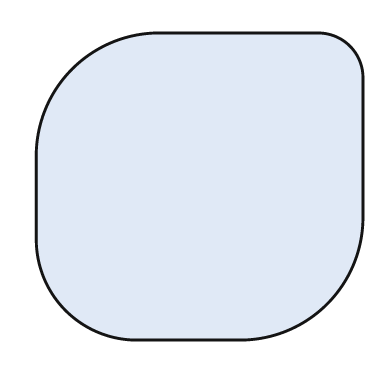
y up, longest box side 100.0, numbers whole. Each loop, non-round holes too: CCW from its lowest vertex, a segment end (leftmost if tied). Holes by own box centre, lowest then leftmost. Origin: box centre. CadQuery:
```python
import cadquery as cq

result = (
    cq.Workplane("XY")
    .moveTo(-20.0, -47.0)
    .lineTo(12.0, -47.0)
    .threePointArc((39.0, -36.0), (50.0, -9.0))
    .lineTo(50.0, 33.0)
    .threePointArc((46.0, 43.0), (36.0, 47.0))
    .lineTo(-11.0, 47.0)
    .threePointArc((-39.0, 36.0), (-50.0, 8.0))
    .lineTo(-50.0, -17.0)
    .threePointArc((-41.0, -38.0), (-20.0, -47.0))
    .close()
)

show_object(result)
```